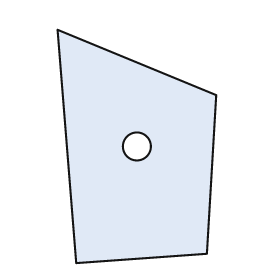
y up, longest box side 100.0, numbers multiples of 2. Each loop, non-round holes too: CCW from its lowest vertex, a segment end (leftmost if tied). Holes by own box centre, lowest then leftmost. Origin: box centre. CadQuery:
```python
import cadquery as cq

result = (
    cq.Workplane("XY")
    .moveTo(-26.0, -50.0)
    .lineTo(30.0, -46.0)
    .lineTo(34.0, 22.0)
    .lineTo(-34.0, 50.0)
    .close()
    .moveTo(0.0, 0.0)
    .circle(6.0)
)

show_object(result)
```